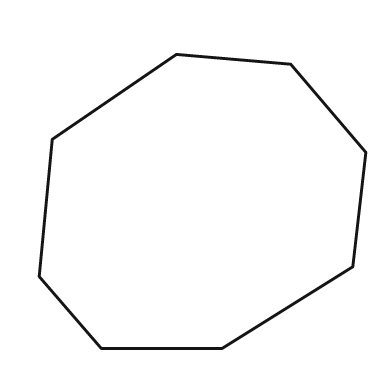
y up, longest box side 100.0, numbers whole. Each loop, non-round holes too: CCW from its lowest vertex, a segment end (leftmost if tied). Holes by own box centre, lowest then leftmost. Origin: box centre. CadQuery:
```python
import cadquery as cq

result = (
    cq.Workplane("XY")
    .moveTo(-31.0, -45.0)
    .lineTo(6.0, -45.0)
    .lineTo(46.0, -20.0)
    .lineTo(50.0, 15.0)
    .lineTo(27.0, 42.0)
    .lineTo(-8.0, 45.0)
    .lineTo(-46.0, 19.0)
    .lineTo(-50.0, -23.0)
    .close()
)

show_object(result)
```